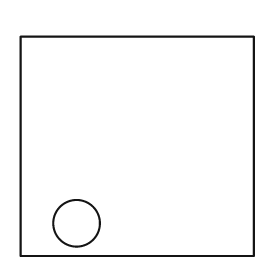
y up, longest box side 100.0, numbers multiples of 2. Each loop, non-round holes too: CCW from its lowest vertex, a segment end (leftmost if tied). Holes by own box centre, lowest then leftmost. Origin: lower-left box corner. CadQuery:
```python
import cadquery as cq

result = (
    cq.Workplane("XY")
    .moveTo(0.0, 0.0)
    .lineTo(100.0, 0.0)
    .lineTo(100.0, 94.0)
    .lineTo(0.0, 94.0)
    .close()
    .moveTo(24.0, 14.0)
    .circle(10.0)
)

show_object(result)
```